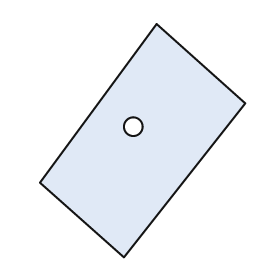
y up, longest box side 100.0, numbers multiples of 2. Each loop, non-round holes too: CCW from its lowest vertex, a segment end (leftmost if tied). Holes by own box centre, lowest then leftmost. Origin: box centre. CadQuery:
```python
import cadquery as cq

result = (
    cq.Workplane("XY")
    .moveTo(-8.0, -50.0)
    .lineTo(44.0, 16.0)
    .lineTo(6.0, 50.0)
    .lineTo(-44.0, -18.0)
    .close()
    .moveTo(-4.0, 6.0)
    .circle(4.0)
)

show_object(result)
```